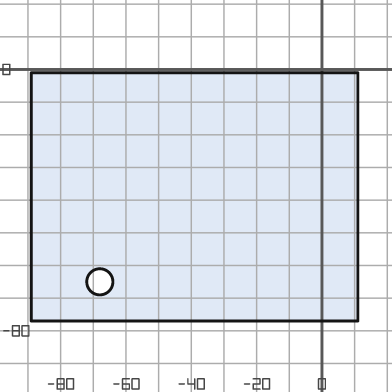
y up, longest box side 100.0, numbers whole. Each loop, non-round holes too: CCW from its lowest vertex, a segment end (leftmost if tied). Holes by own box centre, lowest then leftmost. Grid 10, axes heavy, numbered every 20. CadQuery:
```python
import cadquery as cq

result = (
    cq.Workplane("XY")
    .moveTo(-89.0, -77.0)
    .lineTo(11.0, -77.0)
    .lineTo(11.0, -1.0)
    .lineTo(-89.0, -1.0)
    .close()
    .moveTo(-68.0, -65.0)
    .circle(4.0)
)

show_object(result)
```